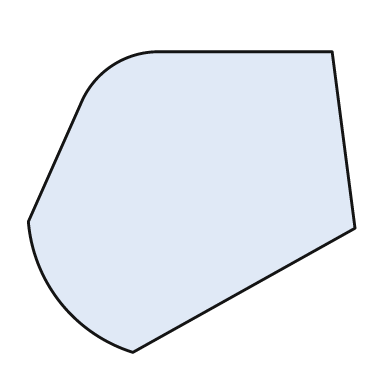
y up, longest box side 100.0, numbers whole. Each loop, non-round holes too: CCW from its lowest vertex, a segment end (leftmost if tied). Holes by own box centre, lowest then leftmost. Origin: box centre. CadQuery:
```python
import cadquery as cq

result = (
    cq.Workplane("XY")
    .moveTo(-18.0, -46.0)
    .lineTo(50.0, -8.0)
    .lineTo(43.0, 46.0)
    .lineTo(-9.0, 46.0)
    .threePointArc((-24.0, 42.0), (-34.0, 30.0))
    .lineTo(-50.0, -6.0)
    .threePointArc((-40.0, -31.0), (-18.0, -46.0))
    .close()
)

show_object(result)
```